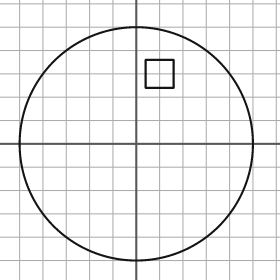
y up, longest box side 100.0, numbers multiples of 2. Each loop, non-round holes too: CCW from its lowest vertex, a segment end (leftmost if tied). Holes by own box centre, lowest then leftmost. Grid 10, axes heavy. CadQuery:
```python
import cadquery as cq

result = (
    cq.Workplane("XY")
    .moveTo(0.0, 0.0)
    .circle(50.0)
    .moveTo(4.0, 24.0)
    .lineTo(16.0, 24.0)
    .lineTo(16.0, 36.0)
    .lineTo(4.0, 36.0)
    .close()
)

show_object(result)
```